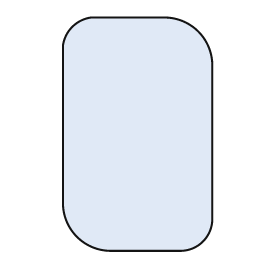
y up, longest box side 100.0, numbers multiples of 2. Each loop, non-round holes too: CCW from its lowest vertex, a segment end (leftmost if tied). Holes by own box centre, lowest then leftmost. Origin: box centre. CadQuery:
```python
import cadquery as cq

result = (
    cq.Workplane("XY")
    .moveTo(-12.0, -50.0)
    .lineTo(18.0, -50.0)
    .threePointArc((28.0, -46.0), (32.0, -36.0))
    .lineTo(32.0, 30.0)
    .threePointArc((26.0, 44.0), (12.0, 50.0))
    .lineTo(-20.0, 50.0)
    .threePointArc((-28.0, 46.0), (-32.0, 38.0))
    .lineTo(-32.0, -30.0)
    .threePointArc((-26.0, -44.0), (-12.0, -50.0))
    .close()
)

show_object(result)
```